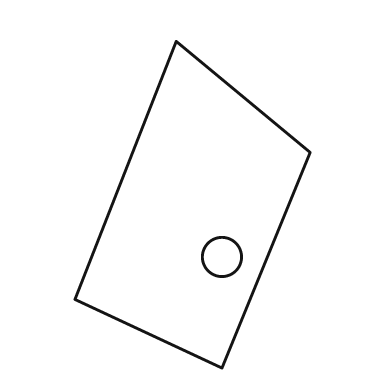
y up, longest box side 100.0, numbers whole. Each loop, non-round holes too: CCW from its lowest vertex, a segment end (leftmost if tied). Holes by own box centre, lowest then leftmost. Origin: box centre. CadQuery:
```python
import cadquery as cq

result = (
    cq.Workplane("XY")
    .moveTo(9.0, -50.0)
    .lineTo(36.0, 16.0)
    .lineTo(-5.0, 50.0)
    .lineTo(-36.0, -29.0)
    .close()
    .moveTo(9.0, -16.0)
    .circle(6.0)
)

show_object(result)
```